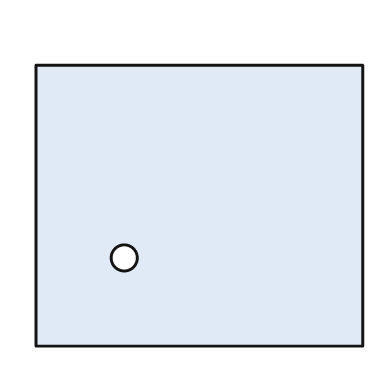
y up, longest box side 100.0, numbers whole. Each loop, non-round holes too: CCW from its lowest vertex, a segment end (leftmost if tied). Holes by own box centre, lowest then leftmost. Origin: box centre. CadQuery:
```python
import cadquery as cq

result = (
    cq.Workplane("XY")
    .moveTo(-50.0, -43.0)
    .lineTo(50.0, -43.0)
    .lineTo(50.0, 43.0)
    .lineTo(-50.0, 43.0)
    .close()
    .moveTo(-23.0, -16.0)
    .circle(4.0)
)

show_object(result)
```